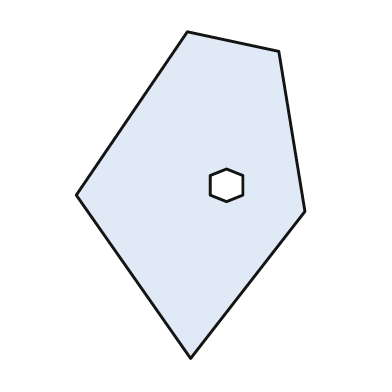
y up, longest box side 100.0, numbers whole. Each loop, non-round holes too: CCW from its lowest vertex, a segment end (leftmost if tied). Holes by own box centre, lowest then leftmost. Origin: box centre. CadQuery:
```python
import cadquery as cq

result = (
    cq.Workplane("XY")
    .moveTo(0.0, -50.0)
    .lineTo(35.0, -5.0)
    .lineTo(27.0, 44.0)
    .lineTo(-1.0, 50.0)
    .lineTo(-35.0, 0.0)
    .close()
    .moveTo(11.0, -2.0)
    .lineTo(16.0, 0.0)
    .lineTo(16.0, 6.0)
    .lineTo(11.0, 8.0)
    .lineTo(6.0, 6.0)
    .lineTo(6.0, 0.0)
    .close()
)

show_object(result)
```